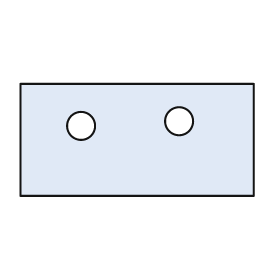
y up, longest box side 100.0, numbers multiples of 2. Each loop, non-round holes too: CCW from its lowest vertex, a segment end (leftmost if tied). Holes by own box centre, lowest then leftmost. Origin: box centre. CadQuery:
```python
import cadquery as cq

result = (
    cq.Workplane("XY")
    .moveTo(-50.0, -24.0)
    .lineTo(50.0, -24.0)
    .lineTo(50.0, 24.0)
    .lineTo(-50.0, 24.0)
    .close()
    .moveTo(-24.0, 6.0)
    .circle(6.0)
    .moveTo(18.0, 8.0)
    .circle(6.0)
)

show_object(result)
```